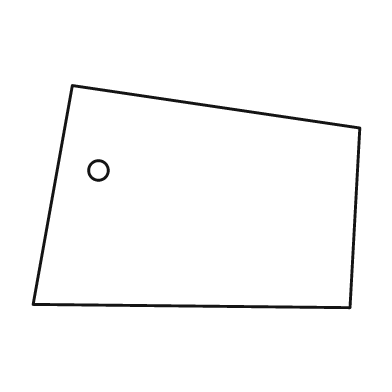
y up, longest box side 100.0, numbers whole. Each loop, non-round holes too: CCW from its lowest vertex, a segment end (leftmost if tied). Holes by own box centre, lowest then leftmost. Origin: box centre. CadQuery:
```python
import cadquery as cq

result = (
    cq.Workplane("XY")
    .moveTo(47.0, -34.0)
    .lineTo(50.0, 21.0)
    .lineTo(-38.0, 34.0)
    .lineTo(-50.0, -33.0)
    .close()
    .moveTo(-30.0, 8.0)
    .circle(3.0)
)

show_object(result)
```